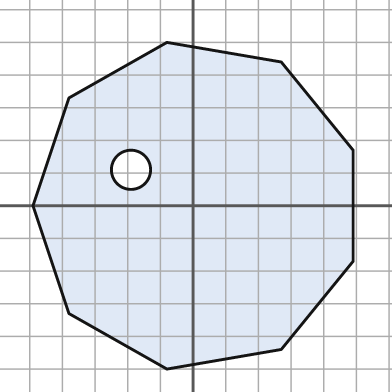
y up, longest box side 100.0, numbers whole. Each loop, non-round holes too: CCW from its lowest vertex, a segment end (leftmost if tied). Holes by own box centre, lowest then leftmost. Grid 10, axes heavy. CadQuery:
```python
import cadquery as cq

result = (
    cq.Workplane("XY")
    .moveTo(-8.0, -50.0)
    .lineTo(27.0, -44.0)
    .lineTo(49.0, -17.0)
    .lineTo(49.0, 17.0)
    .lineTo(27.0, 44.0)
    .lineTo(-8.0, 50.0)
    .lineTo(-38.0, 33.0)
    .lineTo(-49.0, 0.0)
    .lineTo(-38.0, -33.0)
    .close()
    .moveTo(-19.0, 11.0)
    .circle(6.0)
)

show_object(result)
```